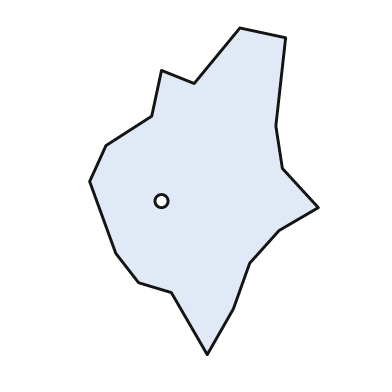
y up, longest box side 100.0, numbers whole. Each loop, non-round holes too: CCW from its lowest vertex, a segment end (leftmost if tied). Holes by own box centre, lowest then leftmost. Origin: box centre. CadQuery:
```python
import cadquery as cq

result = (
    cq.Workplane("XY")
    .moveTo(1.0, -50.0)
    .lineTo(9.0, -36.0)
    .lineTo(14.0, -22.0)
    .lineTo(23.0, -12.0)
    .lineTo(35.0, -5.0)
    .lineTo(24.0, 7.0)
    .lineTo(22.0, 20.0)
    .lineTo(25.0, 47.0)
    .lineTo(11.0, 50.0)
    .lineTo(-3.0, 33.0)
    .lineTo(-13.0, 37.0)
    .lineTo(-16.0, 23.0)
    .lineTo(-30.0, 14.0)
    .lineTo(-35.0, 3.0)
    .lineTo(-27.0, -19.0)
    .lineTo(-20.0, -28.0)
    .lineTo(-10.0, -31.0)
    .close()
    .moveTo(-13.0, -3.0)
    .circle(2.0)
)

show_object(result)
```